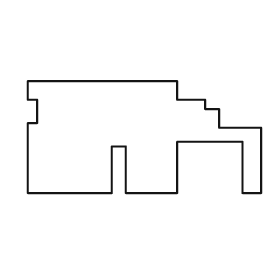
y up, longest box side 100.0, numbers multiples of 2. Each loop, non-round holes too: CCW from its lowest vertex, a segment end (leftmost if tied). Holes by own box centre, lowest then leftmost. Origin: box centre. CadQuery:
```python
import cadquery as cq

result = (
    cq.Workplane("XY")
    .moveTo(-50.0, -24.0)
    .lineTo(-14.0, -24.0)
    .lineTo(-14.0, -4.0)
    .lineTo(-8.0, -4.0)
    .lineTo(-8.0, -24.0)
    .lineTo(14.0, -24.0)
    .lineTo(14.0, -2.0)
    .lineTo(42.0, -2.0)
    .lineTo(42.0, -24.0)
    .lineTo(50.0, -24.0)
    .lineTo(50.0, 4.0)
    .lineTo(32.0, 4.0)
    .lineTo(32.0, 12.0)
    .lineTo(26.0, 12.0)
    .lineTo(26.0, 16.0)
    .lineTo(14.0, 16.0)
    .lineTo(14.0, 24.0)
    .lineTo(-50.0, 24.0)
    .lineTo(-50.0, 16.0)
    .lineTo(-46.0, 16.0)
    .lineTo(-46.0, 6.0)
    .lineTo(-50.0, 6.0)
    .close()
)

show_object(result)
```